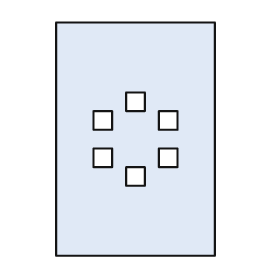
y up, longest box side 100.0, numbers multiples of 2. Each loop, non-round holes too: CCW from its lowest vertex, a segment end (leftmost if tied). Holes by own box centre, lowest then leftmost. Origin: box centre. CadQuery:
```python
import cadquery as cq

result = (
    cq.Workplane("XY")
    .moveTo(-34.0, -50.0)
    .lineTo(34.0, -50.0)
    .lineTo(34.0, 50.0)
    .lineTo(-34.0, 50.0)
    .close()
    .moveTo(-4.0, -20.0)
    .lineTo(4.0, -20.0)
    .lineTo(4.0, -12.0)
    .lineTo(-4.0, -12.0)
    .close()
    .moveTo(-18.0, -12.0)
    .lineTo(-10.0, -12.0)
    .lineTo(-10.0, -4.0)
    .lineTo(-18.0, -4.0)
    .close()
    .moveTo(10.0, -12.0)
    .lineTo(18.0, -12.0)
    .lineTo(18.0, -4.0)
    .lineTo(10.0, -4.0)
    .close()
    .moveTo(-18.0, 4.0)
    .lineTo(-10.0, 4.0)
    .lineTo(-10.0, 12.0)
    .lineTo(-18.0, 12.0)
    .close()
    .moveTo(10.0, 4.0)
    .lineTo(18.0, 4.0)
    .lineTo(18.0, 12.0)
    .lineTo(10.0, 12.0)
    .close()
    .moveTo(-4.0, 12.0)
    .lineTo(4.0, 12.0)
    .lineTo(4.0, 20.0)
    .lineTo(-4.0, 20.0)
    .close()
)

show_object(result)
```